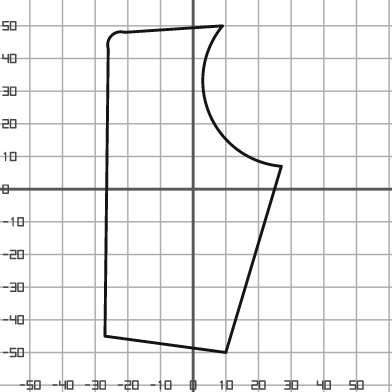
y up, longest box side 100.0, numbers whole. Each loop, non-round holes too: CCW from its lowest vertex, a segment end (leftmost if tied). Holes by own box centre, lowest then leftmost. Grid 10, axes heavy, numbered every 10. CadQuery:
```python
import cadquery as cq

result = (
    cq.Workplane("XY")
    .moveTo(10.0, -50.0)
    .lineTo(27.0, 7.0)
    .threePointArc((5.0, 23.0), (9.0, 50.0))
    .lineTo(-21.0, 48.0)
    .threePointArc((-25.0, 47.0), (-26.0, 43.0))
    .lineTo(-27.0, -45.0)
    .close()
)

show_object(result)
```